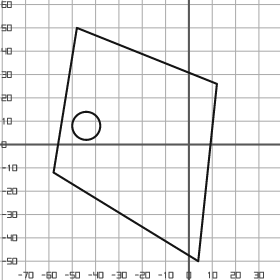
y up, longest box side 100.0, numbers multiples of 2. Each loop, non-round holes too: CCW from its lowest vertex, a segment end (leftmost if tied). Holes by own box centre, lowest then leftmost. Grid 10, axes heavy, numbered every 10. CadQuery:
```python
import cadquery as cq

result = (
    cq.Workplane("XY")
    .moveTo(4.0, -50.0)
    .lineTo(12.0, 26.0)
    .lineTo(-48.0, 50.0)
    .lineTo(-58.0, -12.0)
    .close()
    .moveTo(-44.0, 8.0)
    .circle(6.0)
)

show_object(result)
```